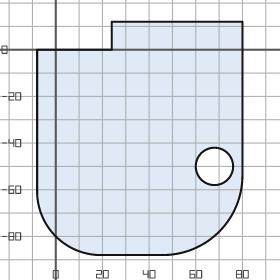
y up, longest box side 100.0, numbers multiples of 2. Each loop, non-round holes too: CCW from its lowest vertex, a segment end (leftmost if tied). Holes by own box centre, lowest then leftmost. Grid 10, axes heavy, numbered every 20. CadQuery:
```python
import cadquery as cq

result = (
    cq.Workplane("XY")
    .moveTo(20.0, -88.0)
    .lineTo(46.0, -88.0)
    .threePointArc((70.0, -78.0), (80.0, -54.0))
    .lineTo(80.0, 12.0)
    .lineTo(24.0, 12.0)
    .lineTo(24.0, 0.0)
    .lineTo(-8.0, 0.0)
    .lineTo(-8.0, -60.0)
    .threePointArc((0.0, -80.0), (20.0, -88.0))
    .close()
    .moveTo(68.0, -50.0)
    .circle(8.0)
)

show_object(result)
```